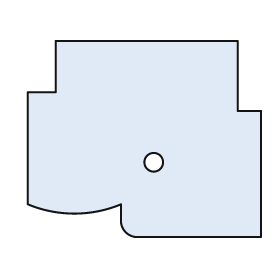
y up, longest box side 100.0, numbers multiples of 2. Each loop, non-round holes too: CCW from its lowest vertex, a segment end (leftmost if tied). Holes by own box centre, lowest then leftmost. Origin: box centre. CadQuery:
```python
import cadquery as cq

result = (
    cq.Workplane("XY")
    .moveTo(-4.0, -42.0)
    .lineTo(50.0, -42.0)
    .lineTo(50.0, 12.0)
    .lineTo(40.0, 12.0)
    .lineTo(40.0, 42.0)
    .lineTo(-38.0, 42.0)
    .lineTo(-38.0, 20.0)
    .lineTo(-50.0, 20.0)
    .lineTo(-50.0, -28.0)
    .threePointArc((-30.0, -32.0), (-10.0, -28.0))
    .lineTo(-10.0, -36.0)
    .threePointArc((-8.0, -40.0), (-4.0, -42.0))
    .close()
    .moveTo(4.0, -10.0)
    .circle(4.0)
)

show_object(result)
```